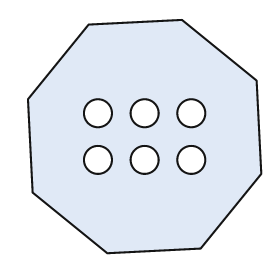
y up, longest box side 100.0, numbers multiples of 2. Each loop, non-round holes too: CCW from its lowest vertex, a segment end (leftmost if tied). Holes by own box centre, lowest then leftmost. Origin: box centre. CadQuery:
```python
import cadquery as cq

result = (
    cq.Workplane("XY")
    .moveTo(-16.0, -50.0)
    .lineTo(24.0, -48.0)
    .lineTo(50.0, -16.0)
    .lineTo(48.0, 24.0)
    .lineTo(16.0, 50.0)
    .lineTo(-24.0, 48.0)
    .lineTo(-50.0, 16.0)
    .lineTo(-48.0, -24.0)
    .close()
    .moveTo(-20.0, -10.0)
    .circle(6.0)
    .moveTo(0.0, -10.0)
    .circle(6.0)
    .moveTo(20.0, -10.0)
    .circle(6.0)
    .moveTo(-20.0, 10.0)
    .circle(6.0)
    .moveTo(0.0, 10.0)
    .circle(6.0)
    .moveTo(20.0, 10.0)
    .circle(6.0)
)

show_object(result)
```